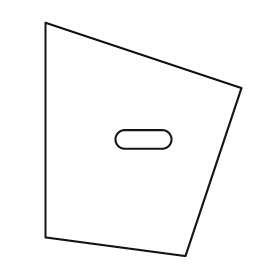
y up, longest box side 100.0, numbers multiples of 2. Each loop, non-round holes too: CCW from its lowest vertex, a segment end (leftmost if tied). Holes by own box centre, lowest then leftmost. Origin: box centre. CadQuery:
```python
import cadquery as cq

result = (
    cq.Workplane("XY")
    .moveTo(18.0, -50.0)
    .lineTo(42.0, 22.0)
    .lineTo(-42.0, 50.0)
    .lineTo(-42.0, -42.0)
    .close()
    .moveTo(-8.0, -4.0)
    .lineTo(8.0, -4.0)
    .threePointArc((12.0, 0.0), (8.0, 4.0))
    .lineTo(-8.0, 4.0)
    .threePointArc((-12.0, 0.0), (-8.0, -4.0))
    .close()
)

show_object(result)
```